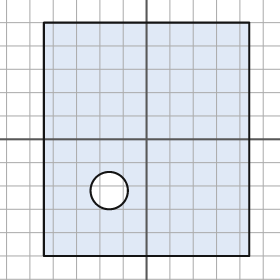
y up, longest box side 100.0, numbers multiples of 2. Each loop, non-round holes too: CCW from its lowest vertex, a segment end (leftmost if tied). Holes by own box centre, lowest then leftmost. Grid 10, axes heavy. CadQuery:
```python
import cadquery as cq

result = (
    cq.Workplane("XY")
    .moveTo(-44.0, -50.0)
    .lineTo(44.0, -50.0)
    .lineTo(44.0, 50.0)
    .lineTo(-44.0, 50.0)
    .close()
    .moveTo(-16.0, -22.0)
    .circle(8.0)
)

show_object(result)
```